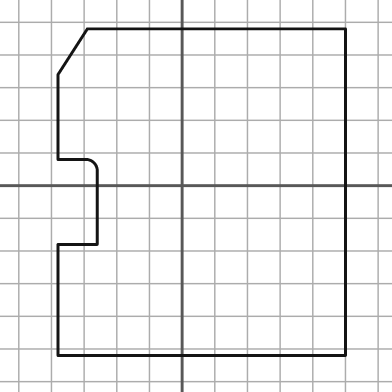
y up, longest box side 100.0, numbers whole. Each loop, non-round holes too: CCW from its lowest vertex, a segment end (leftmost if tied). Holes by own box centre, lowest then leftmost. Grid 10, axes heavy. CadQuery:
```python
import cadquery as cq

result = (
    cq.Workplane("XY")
    .moveTo(-38.0, -52.0)
    .lineTo(50.0, -52.0)
    .lineTo(50.0, 48.0)
    .lineTo(-29.0, 48.0)
    .lineTo(-38.0, 34.0)
    .lineTo(-38.0, 8.0)
    .lineTo(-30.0, 8.0)
    .threePointArc((-27.0, 7.0), (-26.0, 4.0))
    .lineTo(-26.0, -18.0)
    .lineTo(-38.0, -18.0)
    .close()
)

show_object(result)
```